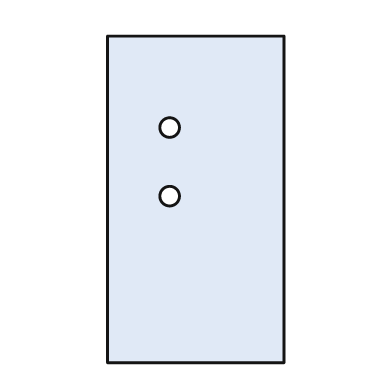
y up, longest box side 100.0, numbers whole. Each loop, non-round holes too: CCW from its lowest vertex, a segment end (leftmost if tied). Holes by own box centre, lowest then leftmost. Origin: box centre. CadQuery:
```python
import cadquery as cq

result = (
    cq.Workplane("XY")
    .moveTo(-27.0, -50.0)
    .lineTo(27.0, -50.0)
    .lineTo(27.0, 50.0)
    .lineTo(-27.0, 50.0)
    .close()
    .moveTo(-8.0, 1.0)
    .circle(3.0)
    .moveTo(-8.0, 22.0)
    .circle(3.0)
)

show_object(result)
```